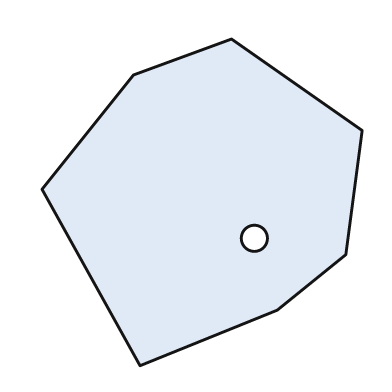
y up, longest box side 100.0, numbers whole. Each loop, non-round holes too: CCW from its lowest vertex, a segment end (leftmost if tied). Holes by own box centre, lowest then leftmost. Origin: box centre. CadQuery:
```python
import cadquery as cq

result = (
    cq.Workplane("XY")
    .moveTo(-19.0, -50.0)
    .lineTo(23.0, -33.0)
    .lineTo(44.0, -16.0)
    .lineTo(49.0, 22.0)
    .lineTo(9.0, 50.0)
    .lineTo(-21.0, 39.0)
    .lineTo(-49.0, 4.0)
    .close()
    .moveTo(16.0, -11.0)
    .circle(4.0)
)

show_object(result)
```